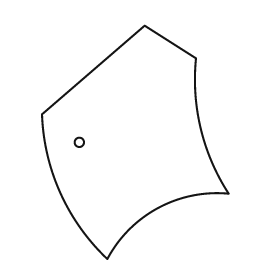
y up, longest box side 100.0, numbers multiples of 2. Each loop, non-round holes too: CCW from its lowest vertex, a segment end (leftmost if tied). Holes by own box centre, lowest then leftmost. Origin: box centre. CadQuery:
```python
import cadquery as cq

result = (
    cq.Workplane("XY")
    .moveTo(-12.0, -50.0)
    .threePointArc((10.0, -28.0), (40.0, -22.0))
    .threePointArc((28.0, 6.0), (26.0, 36.0))
    .lineTo(4.0, 50.0)
    .lineTo(-40.0, 12.0)
    .threePointArc((-32.0, -22.0), (-12.0, -50.0))
    .close()
    .moveTo(-24.0, 0.0)
    .circle(2.0)
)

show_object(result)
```